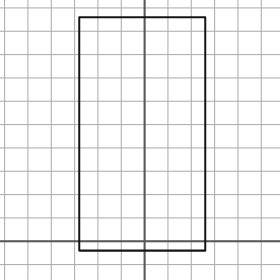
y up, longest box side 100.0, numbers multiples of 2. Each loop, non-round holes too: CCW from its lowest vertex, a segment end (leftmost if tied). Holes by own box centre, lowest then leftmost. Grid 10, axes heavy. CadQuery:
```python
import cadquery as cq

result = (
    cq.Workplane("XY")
    .moveTo(-28.0, -4.0)
    .lineTo(26.0, -4.0)
    .lineTo(26.0, 96.0)
    .lineTo(-28.0, 96.0)
    .close()
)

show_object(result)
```